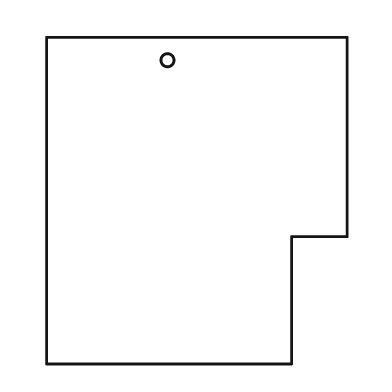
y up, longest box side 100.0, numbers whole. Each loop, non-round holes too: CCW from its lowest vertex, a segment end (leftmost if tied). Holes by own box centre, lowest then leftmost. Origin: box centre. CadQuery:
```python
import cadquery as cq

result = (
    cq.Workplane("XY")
    .moveTo(-46.0, -50.0)
    .lineTo(29.0, -50.0)
    .lineTo(29.0, -11.0)
    .lineTo(46.0, -11.0)
    .lineTo(46.0, 50.0)
    .lineTo(-46.0, 50.0)
    .close()
    .moveTo(-9.0, 43.0)
    .circle(2.0)
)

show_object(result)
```